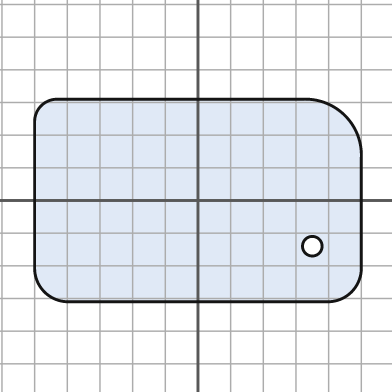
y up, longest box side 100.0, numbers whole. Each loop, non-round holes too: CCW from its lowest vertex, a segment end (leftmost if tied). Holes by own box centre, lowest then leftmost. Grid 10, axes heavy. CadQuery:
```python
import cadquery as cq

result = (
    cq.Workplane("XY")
    .moveTo(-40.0, -31.0)
    .lineTo(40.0, -31.0)
    .threePointArc((47.0, -28.0), (50.0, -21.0))
    .lineTo(50.0, 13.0)
    .threePointArc((45.0, 26.0), (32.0, 31.0))
    .lineTo(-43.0, 31.0)
    .threePointArc((-48.0, 29.0), (-50.0, 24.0))
    .lineTo(-50.0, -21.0)
    .threePointArc((-47.0, -28.0), (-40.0, -31.0))
    .close()
    .moveTo(35.0, -14.0)
    .circle(3.0)
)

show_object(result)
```